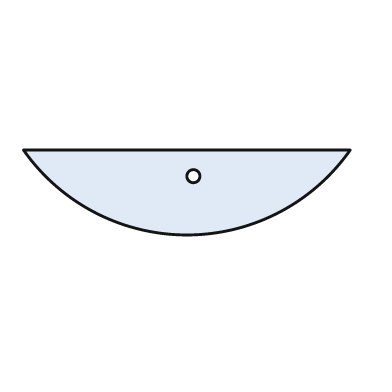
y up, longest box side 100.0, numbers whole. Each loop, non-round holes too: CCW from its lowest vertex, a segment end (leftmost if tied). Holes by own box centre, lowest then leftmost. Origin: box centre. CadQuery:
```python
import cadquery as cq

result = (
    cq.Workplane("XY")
    .moveTo(-50.0, 13.0)
    .threePointArc((0.0, -13.0), (50.0, 13.0))
    .close()
    .moveTo(2.0, 5.0)
    .circle(2.0)
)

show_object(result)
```